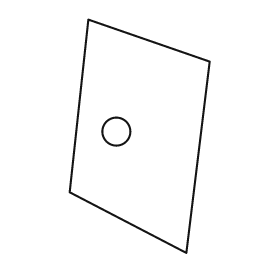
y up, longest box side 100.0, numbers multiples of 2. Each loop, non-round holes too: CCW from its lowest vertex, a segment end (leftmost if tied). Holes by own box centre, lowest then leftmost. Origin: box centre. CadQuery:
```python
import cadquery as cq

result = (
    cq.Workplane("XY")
    .moveTo(20.0, -50.0)
    .lineTo(30.0, 32.0)
    .lineTo(-22.0, 50.0)
    .lineTo(-30.0, -24.0)
    .close()
    .moveTo(-10.0, 2.0)
    .circle(6.0)
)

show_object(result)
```